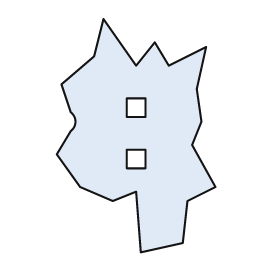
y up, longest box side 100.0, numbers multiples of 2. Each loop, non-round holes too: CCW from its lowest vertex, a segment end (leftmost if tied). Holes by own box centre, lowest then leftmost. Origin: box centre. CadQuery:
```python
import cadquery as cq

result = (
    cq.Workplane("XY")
    .moveTo(2.0, -50.0)
    .lineTo(20.0, -46.0)
    .lineTo(22.0, -28.0)
    .lineTo(34.0, -22.0)
    .lineTo(24.0, -4.0)
    .lineTo(28.0, 6.0)
    .lineTo(26.0, 20.0)
    .lineTo(30.0, 38.0)
    .lineTo(14.0, 30.0)
    .lineTo(8.0, 40.0)
    .lineTo(0.0, 30.0)
    .lineTo(-14.0, 50.0)
    .lineTo(-18.0, 34.0)
    .lineTo(-32.0, 22.0)
    .lineTo(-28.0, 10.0)
    .threePointArc((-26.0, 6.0), (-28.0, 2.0))
    .lineTo(-34.0, -8.0)
    .lineTo(-24.0, -22.0)
    .lineTo(-10.0, -28.0)
    .lineTo(0.0, -24.0)
    .close()
    .moveTo(-4.0, -14.0)
    .lineTo(4.0, -14.0)
    .lineTo(4.0, -6.0)
    .lineTo(-4.0, -6.0)
    .close()
    .moveTo(-4.0, 8.0)
    .lineTo(4.0, 8.0)
    .lineTo(4.0, 16.0)
    .lineTo(-4.0, 16.0)
    .close()
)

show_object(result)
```